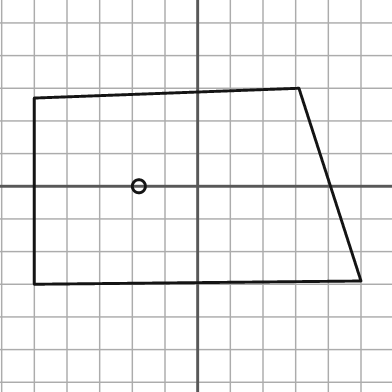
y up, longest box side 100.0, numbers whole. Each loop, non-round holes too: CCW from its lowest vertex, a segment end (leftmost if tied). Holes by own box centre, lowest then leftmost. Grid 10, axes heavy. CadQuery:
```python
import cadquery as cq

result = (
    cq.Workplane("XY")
    .moveTo(-50.0, -30.0)
    .lineTo(50.0, -29.0)
    .lineTo(31.0, 30.0)
    .lineTo(-50.0, 27.0)
    .close()
    .moveTo(-18.0, 0.0)
    .circle(2.0)
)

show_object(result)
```